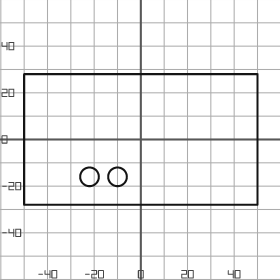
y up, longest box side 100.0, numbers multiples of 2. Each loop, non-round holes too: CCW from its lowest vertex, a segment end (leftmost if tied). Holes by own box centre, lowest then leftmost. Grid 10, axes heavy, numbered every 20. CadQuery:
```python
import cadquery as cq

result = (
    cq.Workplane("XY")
    .moveTo(-50.0, -28.0)
    .lineTo(50.0, -28.0)
    .lineTo(50.0, 28.0)
    .lineTo(-50.0, 28.0)
    .close()
    .moveTo(-22.0, -16.0)
    .circle(4.0)
    .moveTo(-10.0, -16.0)
    .circle(4.0)
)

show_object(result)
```